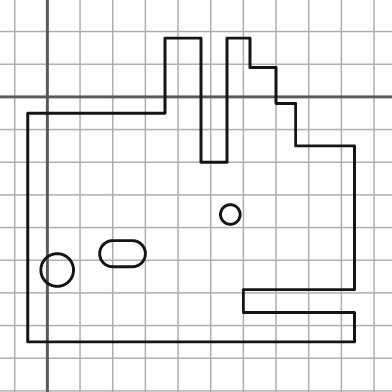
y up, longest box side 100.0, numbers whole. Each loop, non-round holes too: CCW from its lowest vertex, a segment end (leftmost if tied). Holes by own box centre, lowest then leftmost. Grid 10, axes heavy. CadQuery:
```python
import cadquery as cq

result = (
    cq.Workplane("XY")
    .moveTo(-6.0, -75.0)
    .lineTo(94.0, -75.0)
    .lineTo(94.0, -66.0)
    .lineTo(60.0, -66.0)
    .lineTo(60.0, -59.0)
    .lineTo(94.0, -59.0)
    .lineTo(94.0, -15.0)
    .lineTo(76.0, -15.0)
    .lineTo(76.0, -2.0)
    .lineTo(70.0, -2.0)
    .lineTo(70.0, 9.0)
    .lineTo(62.0, 9.0)
    .lineTo(62.0, 18.0)
    .lineTo(55.0, 18.0)
    .lineTo(55.0, -20.0)
    .lineTo(47.0, -20.0)
    .lineTo(47.0, 18.0)
    .lineTo(36.0, 18.0)
    .lineTo(36.0, -5.0)
    .lineTo(-6.0, -5.0)
    .close()
    .moveTo(3.0, -53.0)
    .circle(5.0)
    .moveTo(20.0, -52.0)
    .lineTo(26.0, -52.0)
    .threePointArc((30.0, -48.0), (26.0, -44.0))
    .lineTo(20.0, -44.0)
    .threePointArc((16.0, -48.0), (20.0, -52.0))
    .close()
    .moveTo(56.0, -36.0)
    .circle(3.0)
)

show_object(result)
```